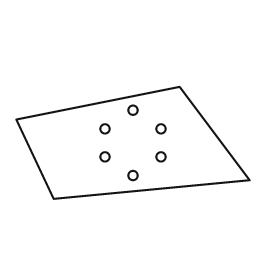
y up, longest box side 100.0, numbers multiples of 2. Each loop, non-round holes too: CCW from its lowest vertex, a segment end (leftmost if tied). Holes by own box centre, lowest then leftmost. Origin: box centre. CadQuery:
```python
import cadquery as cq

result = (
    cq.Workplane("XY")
    .moveTo(-34.0, -24.0)
    .lineTo(50.0, -16.0)
    .lineTo(20.0, 24.0)
    .lineTo(-50.0, 10.0)
    .close()
    .moveTo(0.0, -14.0)
    .circle(2.0)
    .moveTo(-12.0, -6.0)
    .circle(2.0)
    .moveTo(12.0, -6.0)
    .circle(2.0)
    .moveTo(-12.0, 6.0)
    .circle(2.0)
    .moveTo(12.0, 6.0)
    .circle(2.0)
    .moveTo(0.0, 14.0)
    .circle(2.0)
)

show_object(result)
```